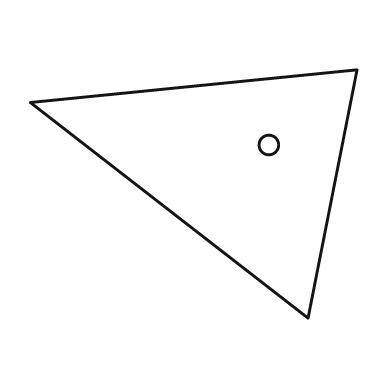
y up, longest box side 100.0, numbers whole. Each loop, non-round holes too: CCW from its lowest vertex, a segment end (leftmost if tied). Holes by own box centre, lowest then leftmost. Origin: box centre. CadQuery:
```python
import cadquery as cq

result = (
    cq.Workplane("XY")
    .moveTo(35.0, -38.0)
    .lineTo(50.0, 38.0)
    .lineTo(-50.0, 28.0)
    .close()
    .moveTo(23.0, 15.0)
    .circle(3.0)
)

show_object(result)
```